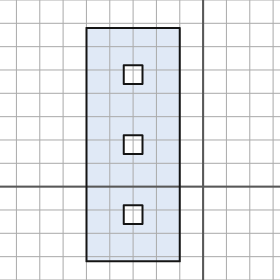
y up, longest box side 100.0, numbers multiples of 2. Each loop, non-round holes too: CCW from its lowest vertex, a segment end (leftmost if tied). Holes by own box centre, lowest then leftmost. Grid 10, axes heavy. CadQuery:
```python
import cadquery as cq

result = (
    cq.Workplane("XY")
    .moveTo(-50.0, -32.0)
    .lineTo(-10.0, -32.0)
    .lineTo(-10.0, 68.0)
    .lineTo(-50.0, 68.0)
    .close()
    .moveTo(-34.0, -16.0)
    .lineTo(-26.0, -16.0)
    .lineTo(-26.0, -8.0)
    .lineTo(-34.0, -8.0)
    .close()
    .moveTo(-34.0, 14.0)
    .lineTo(-26.0, 14.0)
    .lineTo(-26.0, 22.0)
    .lineTo(-34.0, 22.0)
    .close()
    .moveTo(-34.0, 44.0)
    .lineTo(-26.0, 44.0)
    .lineTo(-26.0, 52.0)
    .lineTo(-34.0, 52.0)
    .close()
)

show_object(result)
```